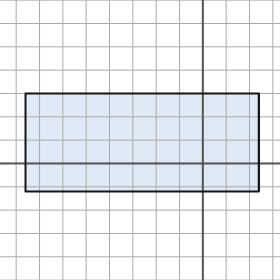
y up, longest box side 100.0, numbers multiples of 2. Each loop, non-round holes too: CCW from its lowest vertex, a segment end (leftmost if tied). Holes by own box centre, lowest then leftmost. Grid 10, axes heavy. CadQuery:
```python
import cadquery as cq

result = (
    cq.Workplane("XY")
    .moveTo(-76.0, -12.0)
    .lineTo(24.0, -12.0)
    .lineTo(24.0, 30.0)
    .lineTo(-76.0, 30.0)
    .close()
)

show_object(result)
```